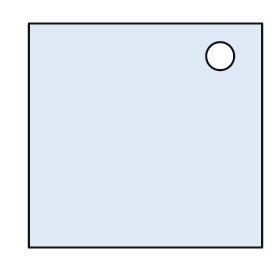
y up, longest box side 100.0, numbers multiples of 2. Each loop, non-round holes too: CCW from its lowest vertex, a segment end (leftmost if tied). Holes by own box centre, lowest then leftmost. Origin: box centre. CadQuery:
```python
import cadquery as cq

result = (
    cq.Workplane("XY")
    .moveTo(-50.0, -48.0)
    .lineTo(50.0, -48.0)
    .lineTo(50.0, 48.0)
    .lineTo(-50.0, 48.0)
    .close()
    .moveTo(32.0, 34.0)
    .circle(6.0)
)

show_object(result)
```